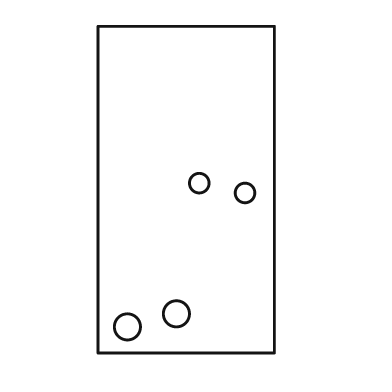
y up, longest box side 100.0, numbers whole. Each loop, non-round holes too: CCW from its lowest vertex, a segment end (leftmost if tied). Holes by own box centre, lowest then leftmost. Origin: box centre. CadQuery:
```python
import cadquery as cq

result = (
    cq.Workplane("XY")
    .moveTo(-27.0, -50.0)
    .lineTo(27.0, -50.0)
    .lineTo(27.0, 50.0)
    .lineTo(-27.0, 50.0)
    .close()
    .moveTo(-18.0, -42.0)
    .circle(4.0)
    .moveTo(-3.0, -38.0)
    .circle(4.0)
    .moveTo(18.0, -1.0)
    .circle(3.0)
    .moveTo(4.0, 2.0)
    .circle(3.0)
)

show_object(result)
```